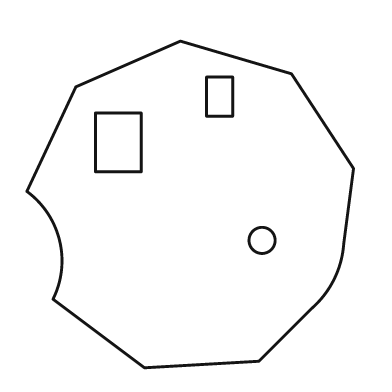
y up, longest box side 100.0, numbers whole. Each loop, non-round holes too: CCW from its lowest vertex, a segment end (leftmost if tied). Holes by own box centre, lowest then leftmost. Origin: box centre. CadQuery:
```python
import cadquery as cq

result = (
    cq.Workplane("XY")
    .moveTo(-14.0, -50.0)
    .lineTo(21.0, -48.0)
    .lineTo(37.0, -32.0)
    .threePointArc((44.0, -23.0), (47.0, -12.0))
    .lineTo(50.0, 11.0)
    .lineTo(31.0, 40.0)
    .lineTo(-3.0, 50.0)
    .lineTo(-35.0, 36.0)
    .lineTo(-50.0, 4.0)
    .threePointArc((-40.0, -11.0), (-42.0, -29.0))
    .close()
    .moveTo(22.0, -11.0)
    .circle(4.0)
    .moveTo(-29.0, 10.0)
    .lineTo(-15.0, 10.0)
    .lineTo(-15.0, 28.0)
    .lineTo(-29.0, 28.0)
    .close()
    .moveTo(5.0, 27.0)
    .lineTo(13.0, 27.0)
    .lineTo(13.0, 39.0)
    .lineTo(5.0, 39.0)
    .close()
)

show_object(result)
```